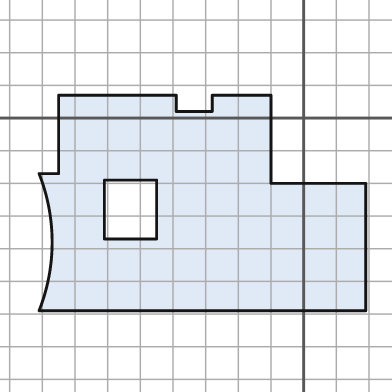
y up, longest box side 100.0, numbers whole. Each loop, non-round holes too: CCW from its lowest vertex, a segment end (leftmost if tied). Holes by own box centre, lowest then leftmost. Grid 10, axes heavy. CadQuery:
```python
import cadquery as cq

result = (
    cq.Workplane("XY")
    .moveTo(-81.0, -59.0)
    .lineTo(19.0, -59.0)
    .lineTo(19.0, -20.0)
    .lineTo(-10.0, -20.0)
    .lineTo(-10.0, 7.0)
    .lineTo(-28.0, 7.0)
    .lineTo(-28.0, 2.0)
    .lineTo(-39.0, 2.0)
    .lineTo(-39.0, 7.0)
    .lineTo(-75.0, 7.0)
    .lineTo(-75.0, -17.0)
    .lineTo(-81.0, -17.0)
    .threePointArc((-77.0, -38.0), (-81.0, -59.0))
    .close()
    .moveTo(-61.0, -37.0)
    .lineTo(-45.0, -37.0)
    .lineTo(-45.0, -19.0)
    .lineTo(-61.0, -19.0)
    .close()
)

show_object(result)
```